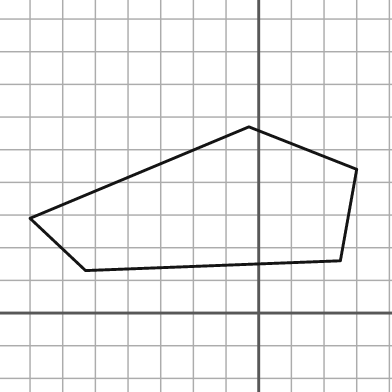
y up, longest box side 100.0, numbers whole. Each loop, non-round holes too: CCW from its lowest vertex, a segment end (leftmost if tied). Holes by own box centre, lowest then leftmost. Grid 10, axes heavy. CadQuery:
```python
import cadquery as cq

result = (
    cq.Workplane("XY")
    .moveTo(-53.0, 13.0)
    .lineTo(25.0, 16.0)
    .lineTo(30.0, 44.0)
    .lineTo(-3.0, 57.0)
    .lineTo(-70.0, 29.0)
    .close()
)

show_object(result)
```